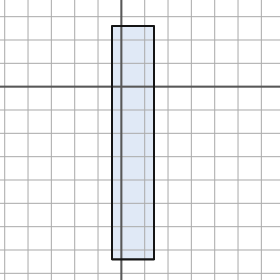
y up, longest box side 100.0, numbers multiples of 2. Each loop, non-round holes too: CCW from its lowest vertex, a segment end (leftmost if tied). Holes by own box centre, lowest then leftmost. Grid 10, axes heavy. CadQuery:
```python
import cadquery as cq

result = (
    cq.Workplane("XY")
    .moveTo(-4.0, -74.0)
    .lineTo(14.0, -74.0)
    .lineTo(14.0, 26.0)
    .lineTo(-4.0, 26.0)
    .close()
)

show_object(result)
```